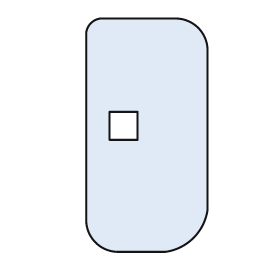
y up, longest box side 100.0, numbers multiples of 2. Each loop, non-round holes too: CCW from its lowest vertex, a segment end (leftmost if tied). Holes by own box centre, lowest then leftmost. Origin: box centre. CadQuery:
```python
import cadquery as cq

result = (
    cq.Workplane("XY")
    .moveTo(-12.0, -50.0)
    .lineTo(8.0, -50.0)
    .threePointArc((20.0, -44.0), (26.0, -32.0))
    .lineTo(26.0, 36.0)
    .threePointArc((22.0, 46.0), (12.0, 50.0))
    .lineTo(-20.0, 50.0)
    .threePointArc((-24.0, 48.0), (-26.0, 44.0))
    .lineTo(-26.0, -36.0)
    .threePointArc((-22.0, -46.0), (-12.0, -50.0))
    .close()
    .moveTo(-16.0, -2.0)
    .lineTo(-4.0, -2.0)
    .lineTo(-4.0, 10.0)
    .lineTo(-16.0, 10.0)
    .close()
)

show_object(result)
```